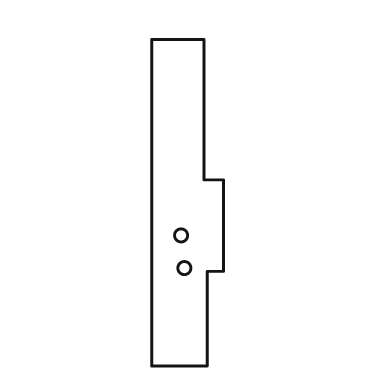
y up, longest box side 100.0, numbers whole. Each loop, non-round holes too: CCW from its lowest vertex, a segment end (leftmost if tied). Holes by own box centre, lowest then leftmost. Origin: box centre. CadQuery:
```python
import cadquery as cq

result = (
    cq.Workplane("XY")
    .moveTo(-11.0, -50.0)
    .lineTo(6.0, -50.0)
    .lineTo(6.0, -21.0)
    .lineTo(11.0, -21.0)
    .lineTo(11.0, 7.0)
    .lineTo(5.0, 7.0)
    .lineTo(5.0, 50.0)
    .lineTo(-11.0, 50.0)
    .close()
    .moveTo(-1.0, -20.0)
    .circle(2.0)
    .moveTo(-2.0, -10.0)
    .circle(2.0)
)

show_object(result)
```